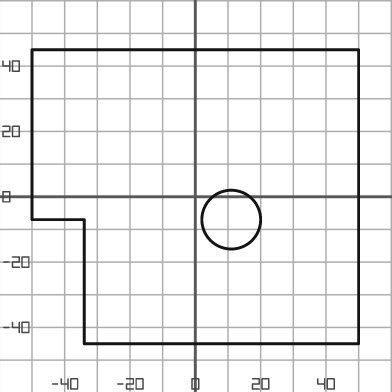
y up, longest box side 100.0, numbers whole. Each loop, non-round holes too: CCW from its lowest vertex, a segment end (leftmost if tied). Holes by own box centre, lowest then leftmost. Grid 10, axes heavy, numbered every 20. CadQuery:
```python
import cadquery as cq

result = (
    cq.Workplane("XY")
    .moveTo(-34.0, -45.0)
    .lineTo(50.0, -45.0)
    .lineTo(50.0, 45.0)
    .lineTo(-50.0, 45.0)
    .lineTo(-50.0, -7.0)
    .lineTo(-34.0, -7.0)
    .close()
    .moveTo(11.0, -7.0)
    .circle(9.0)
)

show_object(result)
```